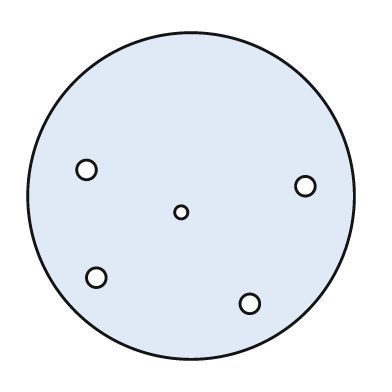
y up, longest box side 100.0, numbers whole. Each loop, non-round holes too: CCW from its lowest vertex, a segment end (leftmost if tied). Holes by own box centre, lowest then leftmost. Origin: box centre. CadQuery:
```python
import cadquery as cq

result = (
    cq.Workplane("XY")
    .moveTo(0.0, 0.0)
    .circle(50.0)
    .moveTo(18.0, -33.0)
    .circle(3.0)
    .moveTo(-29.0, -25.0)
    .circle(3.0)
    .moveTo(-3.0, -5.0)
    .circle(2.0)
    .moveTo(35.0, 3.0)
    .circle(3.0)
    .moveTo(-32.0, 8.0)
    .circle(3.0)
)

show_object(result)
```